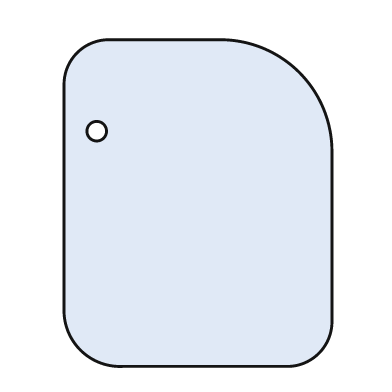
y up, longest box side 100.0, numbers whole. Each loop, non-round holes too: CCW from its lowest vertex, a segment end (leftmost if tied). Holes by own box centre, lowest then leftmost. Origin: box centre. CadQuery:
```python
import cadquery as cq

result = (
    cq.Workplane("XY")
    .moveTo(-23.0, -50.0)
    .lineTo(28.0, -50.0)
    .threePointArc((37.0, -46.0), (41.0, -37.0))
    .lineTo(41.0, 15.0)
    .threePointArc((31.0, 40.0), (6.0, 50.0))
    .lineTo(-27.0, 50.0)
    .threePointArc((-37.0, 46.0), (-41.0, 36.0))
    .lineTo(-41.0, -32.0)
    .threePointArc((-36.0, -45.0), (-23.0, -50.0))
    .close()
    .moveTo(-31.0, 22.0)
    .circle(3.0)
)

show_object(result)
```